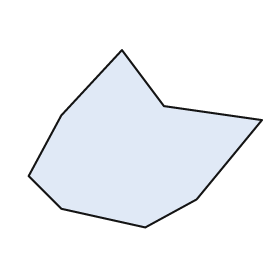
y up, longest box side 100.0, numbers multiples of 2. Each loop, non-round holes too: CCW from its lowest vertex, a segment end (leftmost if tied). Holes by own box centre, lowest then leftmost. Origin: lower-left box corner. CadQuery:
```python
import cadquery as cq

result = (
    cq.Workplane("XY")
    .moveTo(50.0, 0.0)
    .lineTo(72.0, 12.0)
    .lineTo(100.0, 46.0)
    .lineTo(58.0, 52.0)
    .lineTo(40.0, 76.0)
    .lineTo(14.0, 48.0)
    .lineTo(0.0, 22.0)
    .lineTo(14.0, 8.0)
    .close()
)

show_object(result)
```